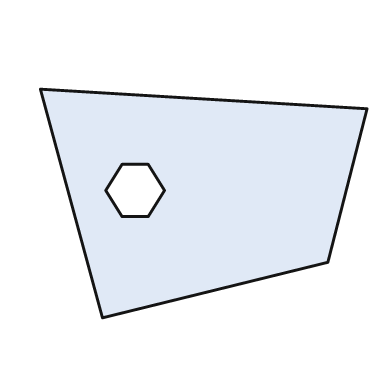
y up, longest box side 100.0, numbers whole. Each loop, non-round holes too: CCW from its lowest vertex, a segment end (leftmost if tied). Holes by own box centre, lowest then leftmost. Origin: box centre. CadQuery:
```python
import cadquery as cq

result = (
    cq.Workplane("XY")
    .moveTo(-31.0, -35.0)
    .lineTo(38.0, -18.0)
    .lineTo(50.0, 29.0)
    .lineTo(-50.0, 35.0)
    .close()
    .moveTo(-25.0, -4.0)
    .lineTo(-17.0, -4.0)
    .lineTo(-12.0, 4.0)
    .lineTo(-17.0, 12.0)
    .lineTo(-25.0, 12.0)
    .lineTo(-30.0, 4.0)
    .close()
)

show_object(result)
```